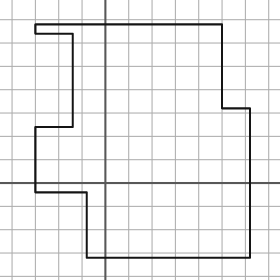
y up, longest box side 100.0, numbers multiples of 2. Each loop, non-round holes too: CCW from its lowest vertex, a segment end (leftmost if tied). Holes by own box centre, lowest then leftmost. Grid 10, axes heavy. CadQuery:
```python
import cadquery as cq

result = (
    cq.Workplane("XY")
    .moveTo(-8.0, -32.0)
    .lineTo(62.0, -32.0)
    .lineTo(62.0, 32.0)
    .lineTo(50.0, 32.0)
    .lineTo(50.0, 68.0)
    .lineTo(-30.0, 68.0)
    .lineTo(-30.0, 64.0)
    .lineTo(-14.0, 64.0)
    .lineTo(-14.0, 24.0)
    .lineTo(-30.0, 24.0)
    .lineTo(-30.0, -4.0)
    .lineTo(-8.0, -4.0)
    .close()
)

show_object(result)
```